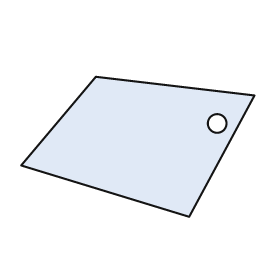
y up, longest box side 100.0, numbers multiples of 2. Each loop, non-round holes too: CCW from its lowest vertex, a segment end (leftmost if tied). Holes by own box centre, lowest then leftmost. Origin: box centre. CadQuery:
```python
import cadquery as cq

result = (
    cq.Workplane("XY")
    .moveTo(22.0, -30.0)
    .lineTo(50.0, 22.0)
    .lineTo(-18.0, 30.0)
    .lineTo(-50.0, -8.0)
    .close()
    .moveTo(34.0, 10.0)
    .circle(4.0)
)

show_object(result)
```